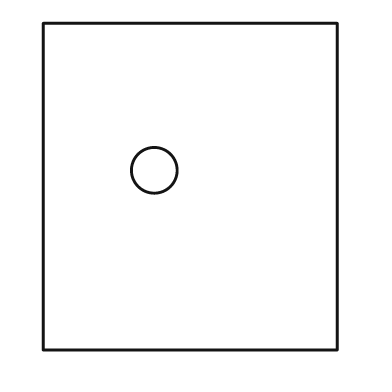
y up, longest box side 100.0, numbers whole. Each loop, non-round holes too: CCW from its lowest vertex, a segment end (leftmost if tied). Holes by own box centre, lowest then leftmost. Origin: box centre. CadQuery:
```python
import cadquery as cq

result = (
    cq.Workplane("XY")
    .moveTo(-45.0, -50.0)
    .lineTo(45.0, -50.0)
    .lineTo(45.0, 50.0)
    .lineTo(-45.0, 50.0)
    .close()
    .moveTo(-11.0, 5.0)
    .circle(7.0)
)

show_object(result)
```